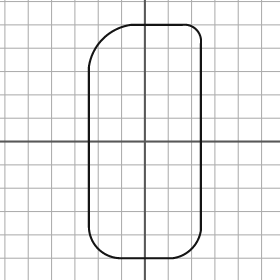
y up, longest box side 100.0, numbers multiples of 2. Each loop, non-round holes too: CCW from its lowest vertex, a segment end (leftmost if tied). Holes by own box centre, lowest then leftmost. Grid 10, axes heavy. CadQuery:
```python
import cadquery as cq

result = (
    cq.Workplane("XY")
    .moveTo(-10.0, -50.0)
    .lineTo(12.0, -50.0)
    .threePointArc((20.0, -46.0), (24.0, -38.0))
    .lineTo(24.0, 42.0)
    .threePointArc((22.0, 48.0), (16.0, 50.0))
    .lineTo(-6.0, 50.0)
    .threePointArc((-18.0, 44.0), (-24.0, 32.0))
    .lineTo(-24.0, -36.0)
    .threePointArc((-20.0, -46.0), (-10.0, -50.0))
    .close()
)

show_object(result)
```